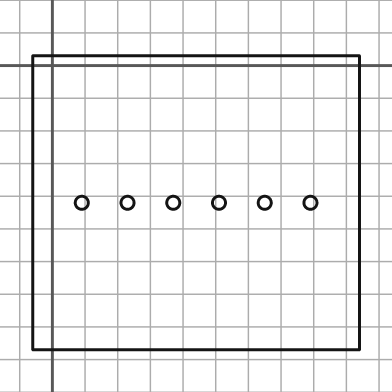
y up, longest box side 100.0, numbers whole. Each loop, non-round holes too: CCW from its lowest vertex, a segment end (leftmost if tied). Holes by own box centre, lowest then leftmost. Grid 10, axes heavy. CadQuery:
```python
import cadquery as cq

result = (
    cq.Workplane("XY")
    .moveTo(-6.0, -87.0)
    .lineTo(94.0, -87.0)
    .lineTo(94.0, 3.0)
    .lineTo(-6.0, 3.0)
    .close()
    .moveTo(9.0, -42.0)
    .circle(2.0)
    .moveTo(23.0, -42.0)
    .circle(2.0)
    .moveTo(37.0, -42.0)
    .circle(2.0)
    .moveTo(51.0, -42.0)
    .circle(2.0)
    .moveTo(65.0, -42.0)
    .circle(2.0)
    .moveTo(79.0, -42.0)
    .circle(2.0)
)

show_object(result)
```